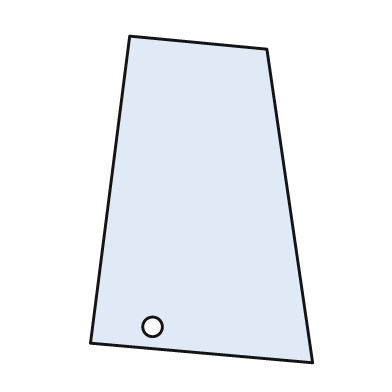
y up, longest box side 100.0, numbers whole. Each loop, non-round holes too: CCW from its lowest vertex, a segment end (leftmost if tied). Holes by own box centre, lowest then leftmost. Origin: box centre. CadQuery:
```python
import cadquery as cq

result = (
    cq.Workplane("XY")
    .moveTo(34.0, -50.0)
    .lineTo(20.0, 46.0)
    .lineTo(-22.0, 50.0)
    .lineTo(-34.0, -44.0)
    .close()
    .moveTo(-15.0, -39.0)
    .circle(3.0)
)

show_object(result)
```